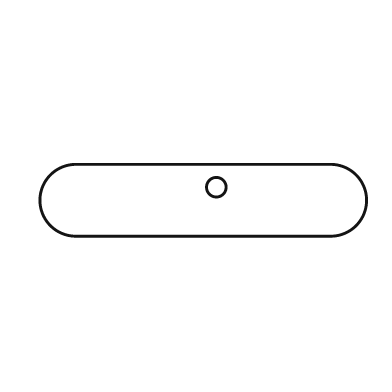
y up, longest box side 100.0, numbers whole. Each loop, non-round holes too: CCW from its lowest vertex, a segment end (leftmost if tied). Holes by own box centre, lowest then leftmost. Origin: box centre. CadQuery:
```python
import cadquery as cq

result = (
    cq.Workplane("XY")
    .moveTo(-39.0, -11.0)
    .lineTo(39.0, -11.0)
    .threePointArc((50.0, 0.0), (39.0, 11.0))
    .lineTo(-39.0, 11.0)
    .threePointArc((-50.0, 0.0), (-39.0, -11.0))
    .close()
    .moveTo(4.0, 4.0)
    .circle(3.0)
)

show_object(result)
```